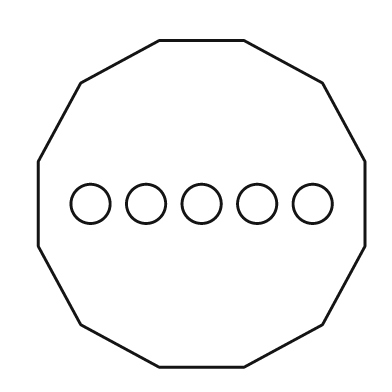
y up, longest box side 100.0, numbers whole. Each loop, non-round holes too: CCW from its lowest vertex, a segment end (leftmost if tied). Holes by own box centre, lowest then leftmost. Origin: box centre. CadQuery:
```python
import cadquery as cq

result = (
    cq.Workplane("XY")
    .moveTo(-13.0, -50.0)
    .lineTo(13.0, -50.0)
    .lineTo(37.0, -37.0)
    .lineTo(50.0, -13.0)
    .lineTo(50.0, 13.0)
    .lineTo(37.0, 37.0)
    .lineTo(13.0, 50.0)
    .lineTo(-13.0, 50.0)
    .lineTo(-37.0, 37.0)
    .lineTo(-50.0, 13.0)
    .lineTo(-50.0, -13.0)
    .lineTo(-37.0, -37.0)
    .close()
    .moveTo(-34.0, 0.0)
    .circle(6.0)
    .moveTo(-17.0, 0.0)
    .circle(6.0)
    .moveTo(0.0, 0.0)
    .circle(6.0)
    .moveTo(17.0, 0.0)
    .circle(6.0)
    .moveTo(34.0, 0.0)
    .circle(6.0)
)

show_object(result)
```